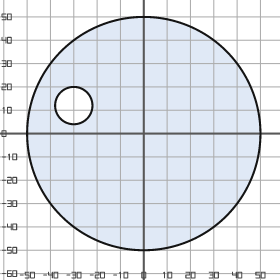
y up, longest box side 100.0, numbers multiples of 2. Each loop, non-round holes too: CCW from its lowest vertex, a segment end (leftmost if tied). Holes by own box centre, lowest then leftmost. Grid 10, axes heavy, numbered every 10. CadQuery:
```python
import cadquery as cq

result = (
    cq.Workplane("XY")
    .moveTo(0.0, 0.0)
    .circle(50.0)
    .moveTo(-30.0, 12.0)
    .circle(8.0)
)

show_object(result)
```